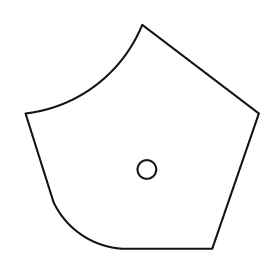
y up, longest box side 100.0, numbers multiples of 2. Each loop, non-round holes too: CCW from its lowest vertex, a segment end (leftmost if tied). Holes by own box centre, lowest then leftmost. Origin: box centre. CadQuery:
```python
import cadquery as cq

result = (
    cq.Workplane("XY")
    .moveTo(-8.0, -48.0)
    .lineTo(30.0, -48.0)
    .lineTo(50.0, 10.0)
    .lineTo(0.0, 48.0)
    .threePointArc((-20.0, 22.0), (-50.0, 10.0))
    .lineTo(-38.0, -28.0)
    .threePointArc((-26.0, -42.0), (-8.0, -48.0))
    .close()
    .moveTo(2.0, -14.0)
    .circle(4.0)
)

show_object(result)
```